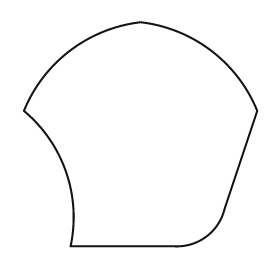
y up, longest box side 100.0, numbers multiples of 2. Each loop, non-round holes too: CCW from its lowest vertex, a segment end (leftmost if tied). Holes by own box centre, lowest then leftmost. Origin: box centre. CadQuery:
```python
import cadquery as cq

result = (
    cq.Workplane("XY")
    .moveTo(-30.0, -48.0)
    .lineTo(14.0, -48.0)
    .threePointArc((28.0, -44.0), (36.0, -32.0))
    .lineTo(50.0, 10.0)
    .threePointArc((30.0, 36.0), (0.0, 48.0))
    .threePointArc((-30.0, 36.0), (-50.0, 10.0))
    .threePointArc((-32.0, -16.0), (-30.0, -48.0))
    .close()
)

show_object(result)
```